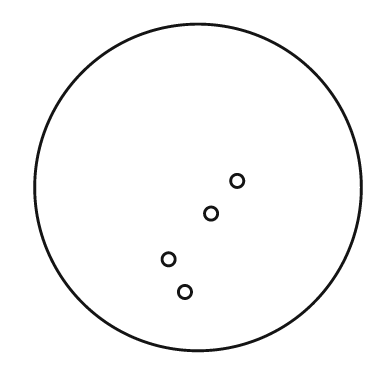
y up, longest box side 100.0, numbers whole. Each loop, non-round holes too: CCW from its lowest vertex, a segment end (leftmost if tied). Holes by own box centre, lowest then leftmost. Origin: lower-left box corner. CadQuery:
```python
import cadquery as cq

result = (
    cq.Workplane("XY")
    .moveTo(50.0, 50.0)
    .circle(50.0)
    .moveTo(46.0, 18.0)
    .circle(2.0)
    .moveTo(41.0, 28.0)
    .circle(2.0)
    .moveTo(54.0, 42.0)
    .circle(2.0)
    .moveTo(62.0, 52.0)
    .circle(2.0)
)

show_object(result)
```